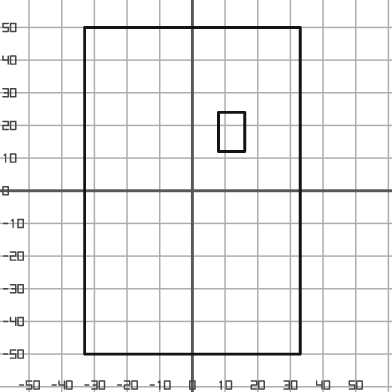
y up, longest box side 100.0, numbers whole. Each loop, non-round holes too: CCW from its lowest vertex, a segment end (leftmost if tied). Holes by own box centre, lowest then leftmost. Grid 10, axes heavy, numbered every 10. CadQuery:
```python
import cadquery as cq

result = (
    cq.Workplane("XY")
    .moveTo(-33.0, -50.0)
    .lineTo(33.0, -50.0)
    .lineTo(33.0, 50.0)
    .lineTo(-33.0, 50.0)
    .close()
    .moveTo(8.0, 12.0)
    .lineTo(16.0, 12.0)
    .lineTo(16.0, 24.0)
    .lineTo(8.0, 24.0)
    .close()
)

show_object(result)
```